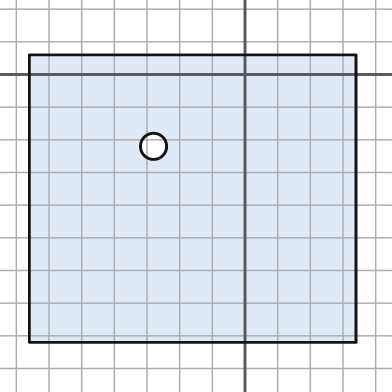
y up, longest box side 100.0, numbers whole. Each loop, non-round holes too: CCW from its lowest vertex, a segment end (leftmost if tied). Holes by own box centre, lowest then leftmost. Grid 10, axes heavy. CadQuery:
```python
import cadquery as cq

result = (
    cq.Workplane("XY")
    .moveTo(-66.0, -82.0)
    .lineTo(34.0, -82.0)
    .lineTo(34.0, 6.0)
    .lineTo(-66.0, 6.0)
    .close()
    .moveTo(-28.0, -22.0)
    .circle(4.0)
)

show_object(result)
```